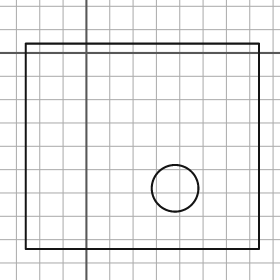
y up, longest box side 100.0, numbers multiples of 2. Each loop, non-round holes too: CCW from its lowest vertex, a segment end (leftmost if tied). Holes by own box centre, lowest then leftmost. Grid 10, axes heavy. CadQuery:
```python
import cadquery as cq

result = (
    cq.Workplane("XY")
    .moveTo(-26.0, -84.0)
    .lineTo(74.0, -84.0)
    .lineTo(74.0, 4.0)
    .lineTo(-26.0, 4.0)
    .close()
    .moveTo(38.0, -58.0)
    .circle(10.0)
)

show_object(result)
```